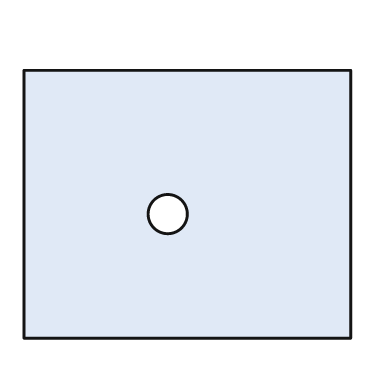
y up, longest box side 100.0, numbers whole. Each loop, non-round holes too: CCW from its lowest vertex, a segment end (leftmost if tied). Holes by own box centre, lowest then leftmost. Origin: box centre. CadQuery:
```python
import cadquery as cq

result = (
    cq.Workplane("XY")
    .moveTo(-50.0, -41.0)
    .lineTo(50.0, -41.0)
    .lineTo(50.0, 41.0)
    .lineTo(-50.0, 41.0)
    .close()
    .moveTo(-6.0, -3.0)
    .circle(6.0)
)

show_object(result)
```